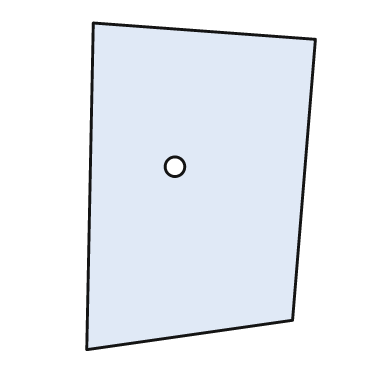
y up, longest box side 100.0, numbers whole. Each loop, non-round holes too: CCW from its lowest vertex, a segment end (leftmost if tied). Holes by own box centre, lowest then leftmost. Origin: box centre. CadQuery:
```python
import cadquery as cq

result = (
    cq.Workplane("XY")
    .moveTo(-35.0, -50.0)
    .lineTo(28.0, -41.0)
    .lineTo(35.0, 45.0)
    .lineTo(-33.0, 50.0)
    .close()
    .moveTo(-8.0, 6.0)
    .circle(3.0)
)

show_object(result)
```